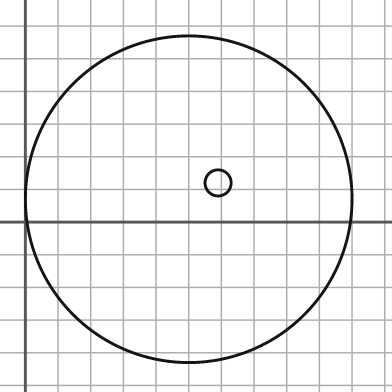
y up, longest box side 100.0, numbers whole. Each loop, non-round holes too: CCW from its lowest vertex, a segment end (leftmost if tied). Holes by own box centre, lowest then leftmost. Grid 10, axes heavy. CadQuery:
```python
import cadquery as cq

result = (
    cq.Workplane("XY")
    .moveTo(50.0, 7.0)
    .circle(50.0)
    .moveTo(59.0, 12.0)
    .circle(4.0)
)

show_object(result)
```